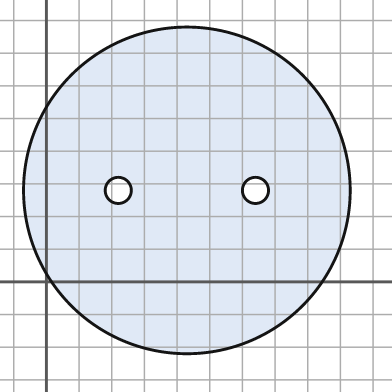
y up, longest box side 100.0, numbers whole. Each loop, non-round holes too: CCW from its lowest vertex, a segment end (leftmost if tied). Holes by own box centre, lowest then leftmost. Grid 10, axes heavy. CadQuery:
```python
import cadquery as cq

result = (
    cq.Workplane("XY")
    .moveTo(43.0, 28.0)
    .circle(50.0)
    .moveTo(22.0, 28.0)
    .circle(4.0)
    .moveTo(64.0, 28.0)
    .circle(4.0)
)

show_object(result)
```